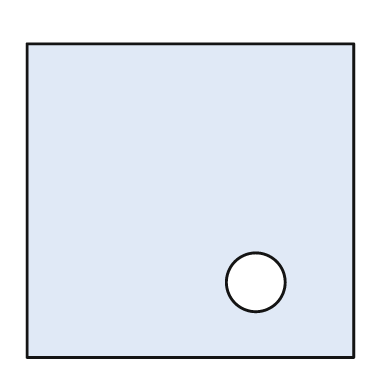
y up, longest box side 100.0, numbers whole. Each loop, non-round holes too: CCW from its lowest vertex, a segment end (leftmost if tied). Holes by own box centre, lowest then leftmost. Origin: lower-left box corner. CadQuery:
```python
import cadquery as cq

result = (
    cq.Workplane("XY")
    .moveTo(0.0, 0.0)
    .lineTo(100.0, 0.0)
    .lineTo(100.0, 96.0)
    .lineTo(0.0, 96.0)
    .close()
    .moveTo(70.0, 23.0)
    .circle(9.0)
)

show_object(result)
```